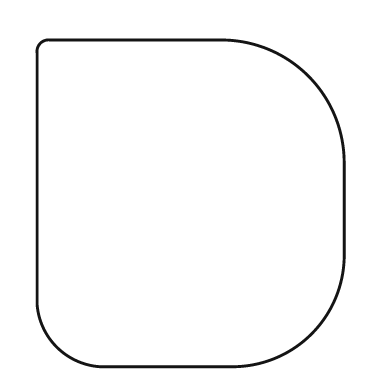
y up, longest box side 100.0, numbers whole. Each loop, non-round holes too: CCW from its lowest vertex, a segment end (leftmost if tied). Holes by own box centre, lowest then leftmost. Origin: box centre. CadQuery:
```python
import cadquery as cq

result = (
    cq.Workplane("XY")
    .moveTo(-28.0, -50.0)
    .lineTo(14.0, -50.0)
    .threePointArc((37.0, -40.0), (47.0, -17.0))
    .lineTo(47.0, 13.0)
    .threePointArc((36.0, 39.0), (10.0, 50.0))
    .lineTo(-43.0, 50.0)
    .threePointArc((-46.0, 49.0), (-47.0, 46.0))
    .lineTo(-47.0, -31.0)
    .threePointArc((-41.0, -44.0), (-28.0, -50.0))
    .close()
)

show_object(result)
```